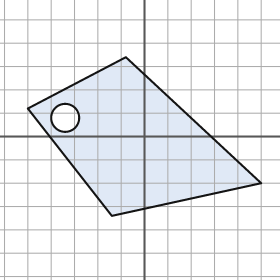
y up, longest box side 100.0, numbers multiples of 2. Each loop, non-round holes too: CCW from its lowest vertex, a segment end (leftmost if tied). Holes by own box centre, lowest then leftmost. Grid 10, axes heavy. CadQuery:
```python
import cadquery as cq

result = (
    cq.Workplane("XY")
    .moveTo(-14.0, -34.0)
    .lineTo(50.0, -20.0)
    .lineTo(-8.0, 34.0)
    .lineTo(-50.0, 12.0)
    .close()
    .moveTo(-34.0, 8.0)
    .circle(6.0)
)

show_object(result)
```